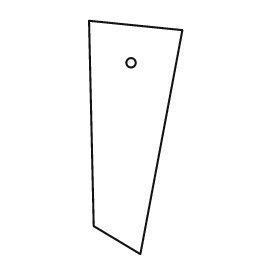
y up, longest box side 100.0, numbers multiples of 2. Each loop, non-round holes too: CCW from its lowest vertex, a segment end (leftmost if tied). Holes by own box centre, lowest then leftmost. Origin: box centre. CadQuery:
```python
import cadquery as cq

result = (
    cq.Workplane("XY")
    .moveTo(2.0, -50.0)
    .lineTo(20.0, 46.0)
    .lineTo(-20.0, 50.0)
    .lineTo(-18.0, -38.0)
    .close()
    .moveTo(-2.0, 32.0)
    .circle(2.0)
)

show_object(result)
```